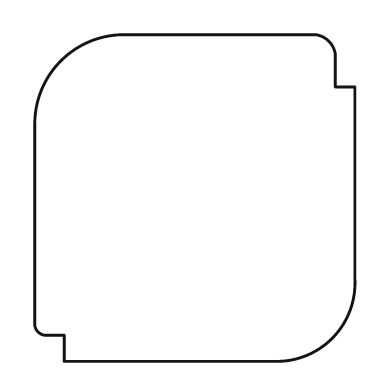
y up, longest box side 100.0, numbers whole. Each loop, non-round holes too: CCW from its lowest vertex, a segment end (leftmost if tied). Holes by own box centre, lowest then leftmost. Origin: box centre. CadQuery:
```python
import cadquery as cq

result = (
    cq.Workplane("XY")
    .moveTo(-40.0, -50.0)
    .lineTo(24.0, -50.0)
    .threePointArc((42.0, -43.0), (49.0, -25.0))
    .lineTo(49.0, 34.0)
    .lineTo(43.0, 34.0)
    .lineTo(43.0, 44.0)
    .threePointArc((41.0, 48.0), (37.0, 50.0))
    .lineTo(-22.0, 50.0)
    .threePointArc((-41.0, 42.0), (-49.0, 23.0))
    .lineTo(-49.0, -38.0)
    .threePointArc((-48.0, -41.0), (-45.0, -42.0))
    .lineTo(-40.0, -42.0)
    .close()
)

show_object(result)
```